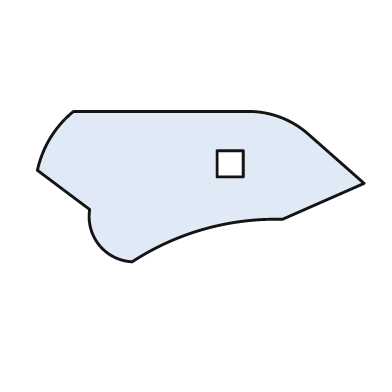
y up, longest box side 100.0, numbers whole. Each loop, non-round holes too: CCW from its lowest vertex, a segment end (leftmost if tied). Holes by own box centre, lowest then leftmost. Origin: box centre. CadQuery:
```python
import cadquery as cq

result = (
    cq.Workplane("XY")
    .moveTo(-21.0, -23.0)
    .threePointArc((1.0, -13.0), (25.0, -10.0))
    .lineTo(50.0, 1.0)
    .lineTo(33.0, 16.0)
    .threePointArc((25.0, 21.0), (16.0, 23.0))
    .lineTo(-39.0, 23.0)
    .threePointArc((-46.0, 15.0), (-50.0, 5.0))
    .lineTo(-34.0, -7.0)
    .threePointArc((-31.0, -18.0), (-21.0, -23.0))
    .close()
    .moveTo(5.0, 3.0)
    .lineTo(13.0, 3.0)
    .lineTo(13.0, 11.0)
    .lineTo(5.0, 11.0)
    .close()
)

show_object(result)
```